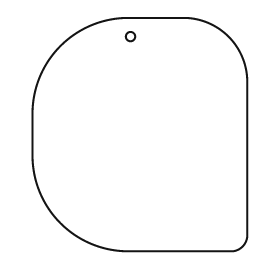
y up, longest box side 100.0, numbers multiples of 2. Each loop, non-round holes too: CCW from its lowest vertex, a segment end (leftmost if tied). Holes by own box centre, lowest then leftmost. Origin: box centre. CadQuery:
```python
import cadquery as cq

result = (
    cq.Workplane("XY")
    .moveTo(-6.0, -50.0)
    .lineTo(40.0, -50.0)
    .threePointArc((44.0, -48.0), (46.0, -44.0))
    .lineTo(46.0, 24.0)
    .threePointArc((38.0, 42.0), (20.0, 50.0))
    .lineTo(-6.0, 50.0)
    .threePointArc((-34.0, 38.0), (-46.0, 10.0))
    .lineTo(-46.0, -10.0)
    .threePointArc((-34.0, -38.0), (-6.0, -50.0))
    .close()
    .moveTo(-4.0, 42.0)
    .circle(2.0)
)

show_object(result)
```